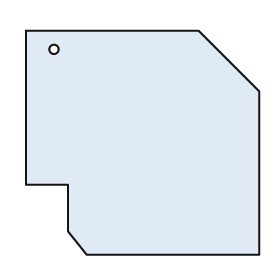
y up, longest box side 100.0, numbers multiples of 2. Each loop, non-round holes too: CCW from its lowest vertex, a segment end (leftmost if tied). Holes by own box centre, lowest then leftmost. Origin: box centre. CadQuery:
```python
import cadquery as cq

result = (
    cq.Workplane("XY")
    .moveTo(-24.0, -48.0)
    .lineTo(50.0, -48.0)
    .lineTo(50.0, 22.0)
    .lineTo(24.0, 48.0)
    .lineTo(-50.0, 48.0)
    .lineTo(-50.0, -18.0)
    .lineTo(-32.0, -18.0)
    .lineTo(-32.0, -38.0)
    .close()
    .moveTo(-38.0, 40.0)
    .circle(2.0)
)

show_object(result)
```